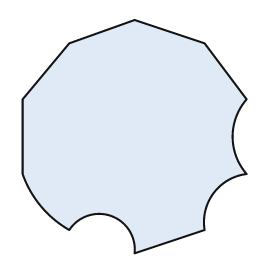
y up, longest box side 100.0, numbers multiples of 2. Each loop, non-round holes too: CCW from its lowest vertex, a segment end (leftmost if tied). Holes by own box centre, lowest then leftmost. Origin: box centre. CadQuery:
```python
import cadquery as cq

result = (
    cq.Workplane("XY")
    .moveTo(0.0, -50.0)
    .lineTo(30.0, -40.0)
    .threePointArc((34.0, -24.0), (48.0, -16.0))
    .threePointArc((42.0, 0.0), (48.0, 16.0))
    .lineTo(30.0, 40.0)
    .lineTo(0.0, 50.0)
    .lineTo(-28.0, 40.0)
    .lineTo(-48.0, 16.0)
    .lineTo(-48.0, -16.0)
    .threePointArc((-40.0, -30.0), (-28.0, -40.0))
    .threePointArc((-10.0, -34.0), (0.0, -50.0))
    .close()
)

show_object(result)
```